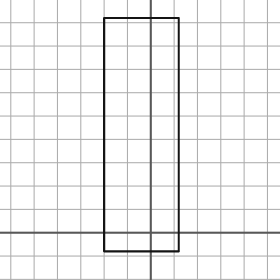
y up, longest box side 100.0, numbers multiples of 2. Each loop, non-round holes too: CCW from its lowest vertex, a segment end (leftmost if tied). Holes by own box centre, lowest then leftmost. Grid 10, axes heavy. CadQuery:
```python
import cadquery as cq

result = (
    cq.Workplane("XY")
    .moveTo(-20.0, -8.0)
    .lineTo(12.0, -8.0)
    .lineTo(12.0, 92.0)
    .lineTo(-20.0, 92.0)
    .close()
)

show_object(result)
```